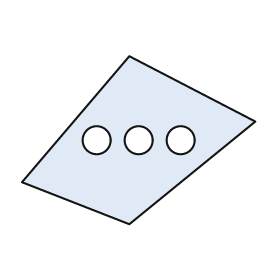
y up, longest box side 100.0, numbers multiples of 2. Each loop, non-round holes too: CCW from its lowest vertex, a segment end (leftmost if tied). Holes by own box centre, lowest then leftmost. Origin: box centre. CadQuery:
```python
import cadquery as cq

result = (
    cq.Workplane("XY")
    .moveTo(-4.0, -36.0)
    .lineTo(50.0, 8.0)
    .lineTo(-4.0, 36.0)
    .lineTo(-50.0, -18.0)
    .close()
    .moveTo(-18.0, 0.0)
    .circle(6.0)
    .moveTo(0.0, 0.0)
    .circle(6.0)
    .moveTo(18.0, 0.0)
    .circle(6.0)
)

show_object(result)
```